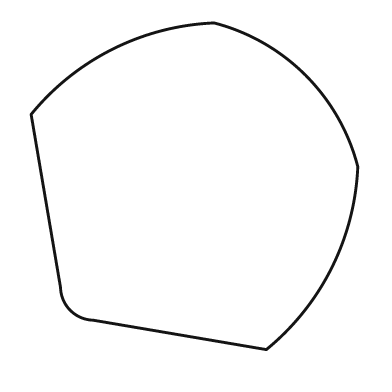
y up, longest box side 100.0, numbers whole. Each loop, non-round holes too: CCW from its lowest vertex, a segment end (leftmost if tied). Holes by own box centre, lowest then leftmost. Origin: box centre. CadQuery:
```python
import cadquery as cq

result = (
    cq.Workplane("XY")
    .moveTo(22.0, -50.0)
    .threePointArc((42.0, -25.0), (50.0, 6.0))
    .threePointArc((34.0, 34.0), (6.0, 50.0))
    .threePointArc((-25.0, 42.0), (-50.0, 22.0))
    .lineTo(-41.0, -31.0)
    .threePointArc((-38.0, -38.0), (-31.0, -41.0))
    .close()
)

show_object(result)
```